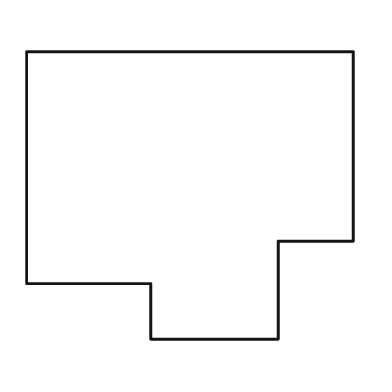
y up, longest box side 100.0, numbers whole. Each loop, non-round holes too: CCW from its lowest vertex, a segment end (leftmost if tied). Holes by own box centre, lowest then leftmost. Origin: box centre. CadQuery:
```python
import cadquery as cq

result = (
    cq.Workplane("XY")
    .moveTo(-12.0, -44.0)
    .lineTo(27.0, -44.0)
    .lineTo(27.0, -14.0)
    .lineTo(50.0, -14.0)
    .lineTo(50.0, 44.0)
    .lineTo(-50.0, 44.0)
    .lineTo(-50.0, -27.0)
    .lineTo(-12.0, -27.0)
    .close()
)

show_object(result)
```